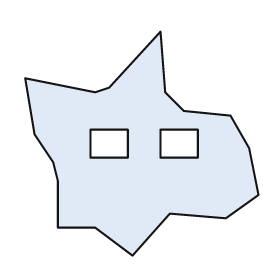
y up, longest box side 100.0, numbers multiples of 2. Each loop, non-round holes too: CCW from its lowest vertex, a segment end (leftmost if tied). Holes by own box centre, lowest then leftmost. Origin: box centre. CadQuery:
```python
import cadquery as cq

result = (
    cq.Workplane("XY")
    .moveTo(-4.0, -48.0)
    .lineTo(12.0, -30.0)
    .lineTo(36.0, -32.0)
    .lineTo(50.0, -22.0)
    .lineTo(46.0, -2.0)
    .lineTo(38.0, 12.0)
    .lineTo(18.0, 14.0)
    .lineTo(10.0, 22.0)
    .lineTo(8.0, 48.0)
    .lineTo(-14.0, 24.0)
    .lineTo(-20.0, 22.0)
    .lineTo(-50.0, 28.0)
    .lineTo(-46.0, 4.0)
    .lineTo(-38.0, -8.0)
    .lineTo(-36.0, -16.0)
    .lineTo(-36.0, -36.0)
    .lineTo(-20.0, -36.0)
    .close()
    .moveTo(-22.0, -6.0)
    .lineTo(-6.0, -6.0)
    .lineTo(-6.0, 6.0)
    .lineTo(-22.0, 6.0)
    .close()
    .moveTo(8.0, -6.0)
    .lineTo(24.0, -6.0)
    .lineTo(24.0, 6.0)
    .lineTo(8.0, 6.0)
    .close()
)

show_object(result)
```